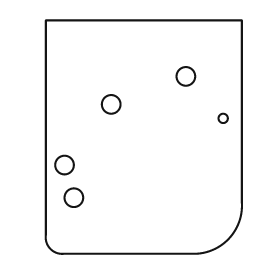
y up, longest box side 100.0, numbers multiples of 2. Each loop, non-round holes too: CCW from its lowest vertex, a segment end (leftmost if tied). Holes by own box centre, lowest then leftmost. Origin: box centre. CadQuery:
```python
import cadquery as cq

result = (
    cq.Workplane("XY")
    .moveTo(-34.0, -50.0)
    .lineTo(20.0, -50.0)
    .threePointArc((36.0, -44.0), (42.0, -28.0))
    .lineTo(42.0, 50.0)
    .lineTo(-42.0, 50.0)
    .lineTo(-42.0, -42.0)
    .threePointArc((-40.0, -48.0), (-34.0, -50.0))
    .close()
    .moveTo(-30.0, -26.0)
    .circle(4.0)
    .moveTo(-34.0, -12.0)
    .circle(4.0)
    .moveTo(34.0, 8.0)
    .circle(2.0)
    .moveTo(-14.0, 14.0)
    .circle(4.0)
    .moveTo(18.0, 26.0)
    .circle(4.0)
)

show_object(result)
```